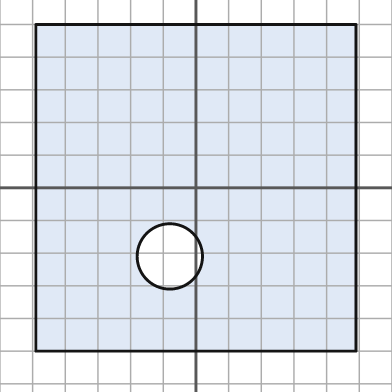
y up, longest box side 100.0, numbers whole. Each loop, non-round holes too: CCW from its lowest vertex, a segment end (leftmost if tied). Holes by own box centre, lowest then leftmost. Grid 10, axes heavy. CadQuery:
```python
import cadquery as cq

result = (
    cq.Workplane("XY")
    .moveTo(-49.0, -50.0)
    .lineTo(49.0, -50.0)
    .lineTo(49.0, 50.0)
    .lineTo(-49.0, 50.0)
    .close()
    .moveTo(-8.0, -21.0)
    .circle(10.0)
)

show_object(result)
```